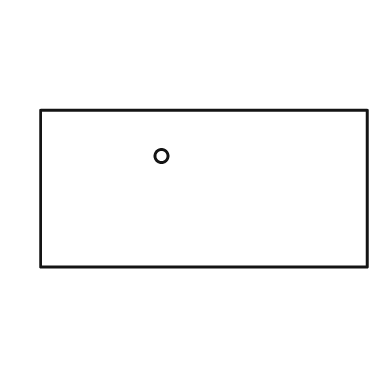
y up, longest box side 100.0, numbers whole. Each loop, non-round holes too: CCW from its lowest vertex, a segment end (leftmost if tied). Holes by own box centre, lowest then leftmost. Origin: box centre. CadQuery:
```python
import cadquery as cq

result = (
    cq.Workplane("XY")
    .moveTo(-50.0, -24.0)
    .lineTo(50.0, -24.0)
    .lineTo(50.0, 24.0)
    .lineTo(-50.0, 24.0)
    .close()
    .moveTo(-13.0, 10.0)
    .circle(2.0)
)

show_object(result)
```